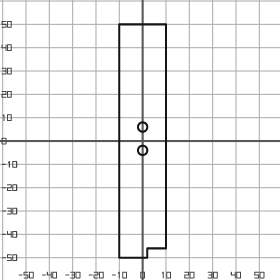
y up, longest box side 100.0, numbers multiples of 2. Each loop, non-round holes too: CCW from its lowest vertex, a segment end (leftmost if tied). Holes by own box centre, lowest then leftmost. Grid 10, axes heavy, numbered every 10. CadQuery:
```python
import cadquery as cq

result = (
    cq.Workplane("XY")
    .moveTo(-10.0, -50.0)
    .lineTo(2.0, -50.0)
    .lineTo(2.0, -46.0)
    .lineTo(10.0, -46.0)
    .lineTo(10.0, 50.0)
    .lineTo(-10.0, 50.0)
    .close()
    .moveTo(0.0, -4.0)
    .circle(2.0)
    .moveTo(0.0, 6.0)
    .circle(2.0)
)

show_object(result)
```